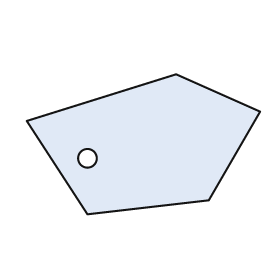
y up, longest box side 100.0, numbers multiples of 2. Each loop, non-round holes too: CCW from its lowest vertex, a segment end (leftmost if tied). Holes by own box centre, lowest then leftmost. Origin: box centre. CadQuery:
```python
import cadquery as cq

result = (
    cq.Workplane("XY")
    .moveTo(-24.0, -30.0)
    .lineTo(28.0, -24.0)
    .lineTo(50.0, 14.0)
    .lineTo(14.0, 30.0)
    .lineTo(-50.0, 10.0)
    .close()
    .moveTo(-24.0, -6.0)
    .circle(4.0)
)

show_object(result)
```